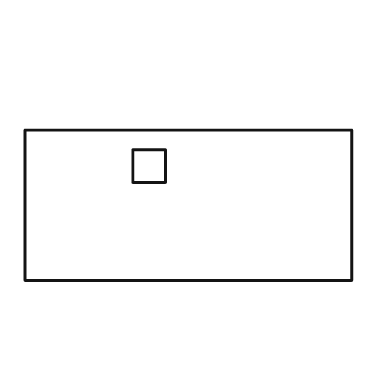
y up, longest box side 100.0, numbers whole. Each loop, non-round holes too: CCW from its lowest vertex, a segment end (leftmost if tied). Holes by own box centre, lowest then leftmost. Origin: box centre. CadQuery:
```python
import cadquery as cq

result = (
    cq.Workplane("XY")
    .moveTo(-50.0, -23.0)
    .lineTo(50.0, -23.0)
    .lineTo(50.0, 23.0)
    .lineTo(-50.0, 23.0)
    .close()
    .moveTo(-17.0, 7.0)
    .lineTo(-7.0, 7.0)
    .lineTo(-7.0, 17.0)
    .lineTo(-17.0, 17.0)
    .close()
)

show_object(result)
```